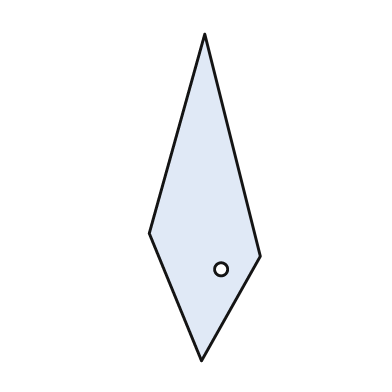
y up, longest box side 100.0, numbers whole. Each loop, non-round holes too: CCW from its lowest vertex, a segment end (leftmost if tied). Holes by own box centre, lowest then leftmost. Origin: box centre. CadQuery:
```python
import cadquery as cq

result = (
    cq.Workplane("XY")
    .moveTo(-1.0, -50.0)
    .lineTo(17.0, -18.0)
    .lineTo(0.0, 50.0)
    .lineTo(-17.0, -11.0)
    .close()
    .moveTo(5.0, -22.0)
    .circle(2.0)
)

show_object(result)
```